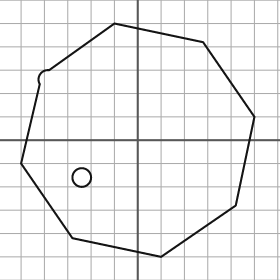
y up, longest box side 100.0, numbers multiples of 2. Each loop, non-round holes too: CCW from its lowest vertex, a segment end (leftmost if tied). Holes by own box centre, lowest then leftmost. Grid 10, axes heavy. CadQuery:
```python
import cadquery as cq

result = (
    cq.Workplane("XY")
    .moveTo(10.0, -50.0)
    .lineTo(42.0, -28.0)
    .lineTo(50.0, 10.0)
    .lineTo(28.0, 42.0)
    .lineTo(-10.0, 50.0)
    .lineTo(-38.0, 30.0)
    .threePointArc((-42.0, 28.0), (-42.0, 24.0))
    .lineTo(-50.0, -10.0)
    .lineTo(-28.0, -42.0)
    .close()
    .moveTo(-24.0, -16.0)
    .circle(4.0)
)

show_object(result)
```